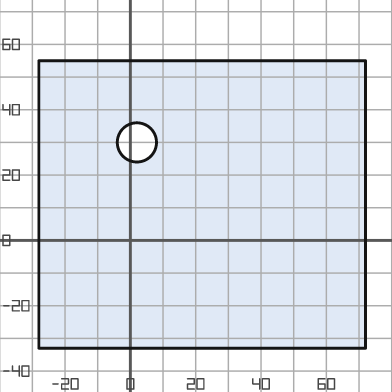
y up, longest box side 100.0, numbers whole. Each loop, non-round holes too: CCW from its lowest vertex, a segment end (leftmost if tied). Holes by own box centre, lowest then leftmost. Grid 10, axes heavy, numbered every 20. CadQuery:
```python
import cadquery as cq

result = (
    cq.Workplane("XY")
    .moveTo(-28.0, -33.0)
    .lineTo(72.0, -33.0)
    .lineTo(72.0, 55.0)
    .lineTo(-28.0, 55.0)
    .close()
    .moveTo(2.0, 30.0)
    .circle(6.0)
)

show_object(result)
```